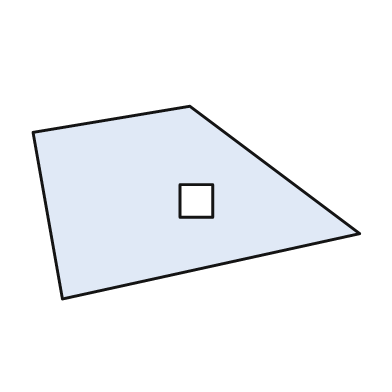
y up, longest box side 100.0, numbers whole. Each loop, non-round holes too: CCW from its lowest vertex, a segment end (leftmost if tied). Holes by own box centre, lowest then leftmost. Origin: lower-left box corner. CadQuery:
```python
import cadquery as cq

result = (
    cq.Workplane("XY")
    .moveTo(9.0, 0.0)
    .lineTo(100.0, 20.0)
    .lineTo(48.0, 59.0)
    .lineTo(0.0, 51.0)
    .close()
    .moveTo(45.0, 25.0)
    .lineTo(55.0, 25.0)
    .lineTo(55.0, 35.0)
    .lineTo(45.0, 35.0)
    .close()
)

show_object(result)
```